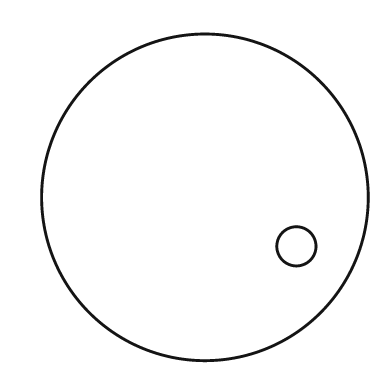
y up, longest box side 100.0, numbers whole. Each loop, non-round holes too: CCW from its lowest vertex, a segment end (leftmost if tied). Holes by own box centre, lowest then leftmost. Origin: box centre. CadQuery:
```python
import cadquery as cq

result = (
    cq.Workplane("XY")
    .moveTo(0.0, 0.0)
    .circle(50.0)
    .moveTo(28.0, -15.0)
    .circle(6.0)
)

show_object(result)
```